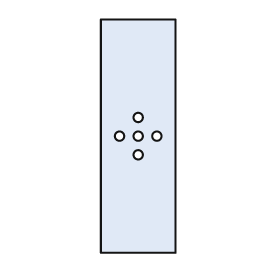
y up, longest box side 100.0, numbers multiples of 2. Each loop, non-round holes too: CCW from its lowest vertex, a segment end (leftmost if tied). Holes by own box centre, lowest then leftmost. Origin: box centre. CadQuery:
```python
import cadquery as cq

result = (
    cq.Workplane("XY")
    .moveTo(-16.0, -50.0)
    .lineTo(16.0, -50.0)
    .lineTo(16.0, 50.0)
    .lineTo(-16.0, 50.0)
    .close()
    .moveTo(0.0, -8.0)
    .circle(2.0)
    .moveTo(-8.0, 0.0)
    .circle(2.0)
    .moveTo(0.0, 0.0)
    .circle(2.0)
    .moveTo(8.0, 0.0)
    .circle(2.0)
    .moveTo(0.0, 8.0)
    .circle(2.0)
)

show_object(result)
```